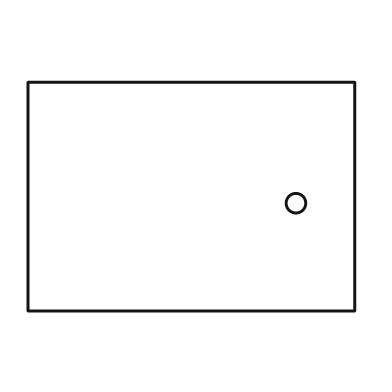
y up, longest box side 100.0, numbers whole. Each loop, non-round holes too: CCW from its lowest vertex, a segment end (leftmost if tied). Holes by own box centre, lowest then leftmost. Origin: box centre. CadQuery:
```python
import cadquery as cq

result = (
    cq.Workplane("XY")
    .moveTo(-50.0, -35.0)
    .lineTo(50.0, -35.0)
    .lineTo(50.0, 35.0)
    .lineTo(-50.0, 35.0)
    .close()
    .moveTo(32.0, -2.0)
    .circle(3.0)
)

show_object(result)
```